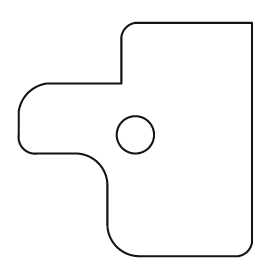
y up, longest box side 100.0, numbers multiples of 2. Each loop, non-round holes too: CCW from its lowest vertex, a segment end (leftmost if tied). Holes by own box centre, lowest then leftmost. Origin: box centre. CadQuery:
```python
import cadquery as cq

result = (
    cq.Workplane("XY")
    .moveTo(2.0, -50.0)
    .lineTo(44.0, -50.0)
    .threePointArc((48.0, -48.0), (50.0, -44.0))
    .lineTo(50.0, 50.0)
    .lineTo(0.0, 50.0)
    .threePointArc((-4.0, 48.0), (-6.0, 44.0))
    .lineTo(-6.0, 24.0)
    .lineTo(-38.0, 24.0)
    .threePointArc((-46.0, 20.0), (-50.0, 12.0))
    .lineTo(-50.0, 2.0)
    .threePointArc((-48.0, -4.0), (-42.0, -6.0))
    .lineTo(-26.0, -6.0)
    .threePointArc((-16.0, -10.0), (-12.0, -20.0))
    .lineTo(-12.0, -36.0)
    .threePointArc((-8.0, -46.0), (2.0, -50.0))
    .close()
    .moveTo(0.0, 2.0)
    .circle(8.0)
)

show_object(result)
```